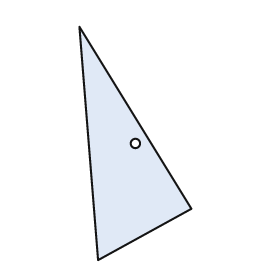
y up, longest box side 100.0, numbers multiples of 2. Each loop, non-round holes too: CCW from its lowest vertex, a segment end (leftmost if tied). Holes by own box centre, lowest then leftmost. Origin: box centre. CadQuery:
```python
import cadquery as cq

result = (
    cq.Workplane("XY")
    .moveTo(-16.0, -50.0)
    .lineTo(24.0, -28.0)
    .lineTo(-24.0, 50.0)
    .close()
    .moveTo(0.0, 0.0)
    .circle(2.0)
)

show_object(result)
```